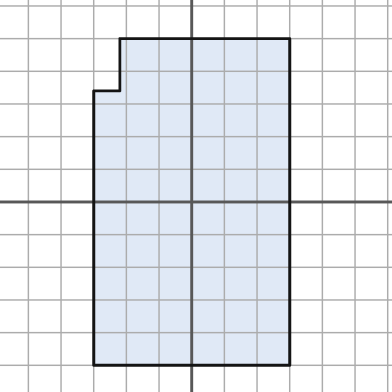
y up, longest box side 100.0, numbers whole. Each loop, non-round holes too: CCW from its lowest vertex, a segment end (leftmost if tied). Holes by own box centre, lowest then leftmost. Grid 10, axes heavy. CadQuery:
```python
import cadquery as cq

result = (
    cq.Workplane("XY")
    .moveTo(-30.0, -50.0)
    .lineTo(30.0, -50.0)
    .lineTo(30.0, 50.0)
    .lineTo(-22.0, 50.0)
    .lineTo(-22.0, 34.0)
    .lineTo(-30.0, 34.0)
    .close()
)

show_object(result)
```